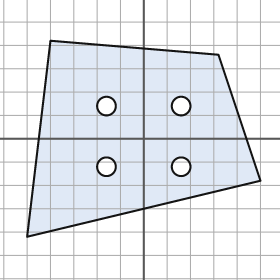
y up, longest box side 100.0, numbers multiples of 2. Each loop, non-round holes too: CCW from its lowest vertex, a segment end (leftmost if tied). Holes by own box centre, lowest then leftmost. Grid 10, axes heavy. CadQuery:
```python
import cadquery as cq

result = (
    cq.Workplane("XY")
    .moveTo(-50.0, -42.0)
    .lineTo(50.0, -18.0)
    .lineTo(32.0, 36.0)
    .lineTo(-40.0, 42.0)
    .close()
    .moveTo(-16.0, -12.0)
    .circle(4.0)
    .moveTo(16.0, -12.0)
    .circle(4.0)
    .moveTo(-16.0, 14.0)
    .circle(4.0)
    .moveTo(16.0, 14.0)
    .circle(4.0)
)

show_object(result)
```